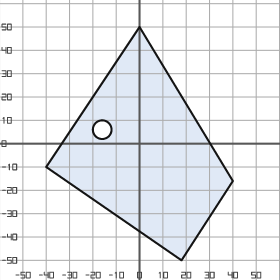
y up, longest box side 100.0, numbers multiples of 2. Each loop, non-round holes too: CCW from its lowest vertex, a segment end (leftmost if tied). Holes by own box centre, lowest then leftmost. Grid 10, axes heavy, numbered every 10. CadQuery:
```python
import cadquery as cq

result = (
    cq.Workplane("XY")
    .moveTo(18.0, -50.0)
    .lineTo(40.0, -16.0)
    .lineTo(0.0, 50.0)
    .lineTo(-40.0, -10.0)
    .close()
    .moveTo(-16.0, 6.0)
    .circle(4.0)
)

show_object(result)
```